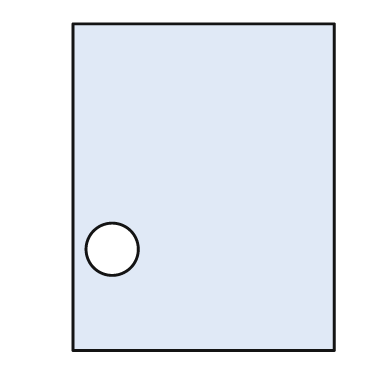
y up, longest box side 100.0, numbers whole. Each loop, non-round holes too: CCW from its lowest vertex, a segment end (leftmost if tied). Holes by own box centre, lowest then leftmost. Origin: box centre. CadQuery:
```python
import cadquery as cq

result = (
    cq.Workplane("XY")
    .moveTo(-40.0, -50.0)
    .lineTo(40.0, -50.0)
    .lineTo(40.0, 50.0)
    .lineTo(-40.0, 50.0)
    .close()
    .moveTo(-28.0, -19.0)
    .circle(8.0)
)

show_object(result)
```